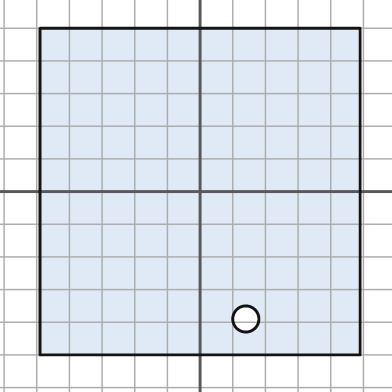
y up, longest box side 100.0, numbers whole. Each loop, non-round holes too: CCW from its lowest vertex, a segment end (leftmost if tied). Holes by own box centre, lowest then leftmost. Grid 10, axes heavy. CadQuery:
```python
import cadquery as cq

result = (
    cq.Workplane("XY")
    .moveTo(-49.0, -50.0)
    .lineTo(49.0, -50.0)
    .lineTo(49.0, 50.0)
    .lineTo(-49.0, 50.0)
    .close()
    .moveTo(14.0, -39.0)
    .circle(4.0)
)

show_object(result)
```